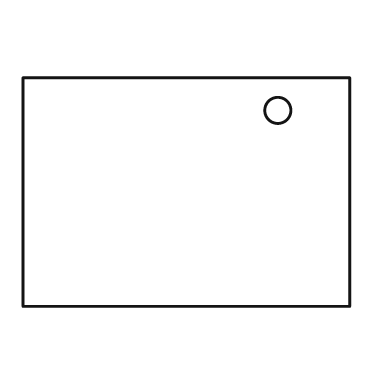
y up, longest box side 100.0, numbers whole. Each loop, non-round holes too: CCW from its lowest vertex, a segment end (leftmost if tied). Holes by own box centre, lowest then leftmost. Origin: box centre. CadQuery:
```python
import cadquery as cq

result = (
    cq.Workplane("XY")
    .moveTo(-50.0, -35.0)
    .lineTo(50.0, -35.0)
    .lineTo(50.0, 35.0)
    .lineTo(-50.0, 35.0)
    .close()
    .moveTo(28.0, 25.0)
    .circle(4.0)
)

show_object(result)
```